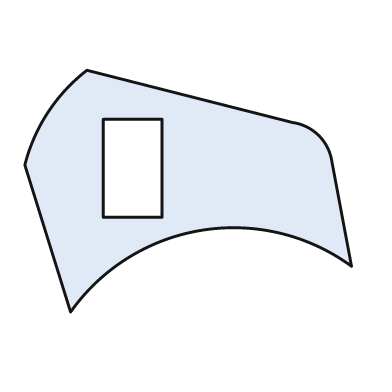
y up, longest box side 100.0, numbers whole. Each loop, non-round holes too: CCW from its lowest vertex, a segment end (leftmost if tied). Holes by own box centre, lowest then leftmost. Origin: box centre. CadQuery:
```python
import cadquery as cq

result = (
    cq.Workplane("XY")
    .moveTo(-36.0, -37.0)
    .threePointArc((4.0, -12.0), (50.0, -23.0))
    .lineTo(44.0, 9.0)
    .threePointArc((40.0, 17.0), (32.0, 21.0))
    .lineTo(-31.0, 37.0)
    .threePointArc((-43.0, 24.0), (-50.0, 8.0))
    .close()
    .moveTo(-26.0, -8.0)
    .lineTo(-8.0, -8.0)
    .lineTo(-8.0, 22.0)
    .lineTo(-26.0, 22.0)
    .close()
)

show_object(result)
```